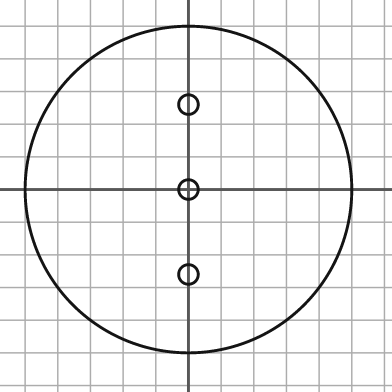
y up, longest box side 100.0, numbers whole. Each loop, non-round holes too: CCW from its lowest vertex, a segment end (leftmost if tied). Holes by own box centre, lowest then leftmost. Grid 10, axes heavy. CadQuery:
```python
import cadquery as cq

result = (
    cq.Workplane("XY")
    .moveTo(0.0, 0.0)
    .circle(50.0)
    .moveTo(0.0, -26.0)
    .circle(3.0)
    .moveTo(0.0, 0.0)
    .circle(3.0)
    .moveTo(0.0, 26.0)
    .circle(3.0)
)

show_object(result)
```